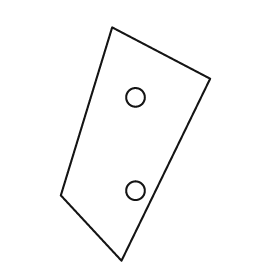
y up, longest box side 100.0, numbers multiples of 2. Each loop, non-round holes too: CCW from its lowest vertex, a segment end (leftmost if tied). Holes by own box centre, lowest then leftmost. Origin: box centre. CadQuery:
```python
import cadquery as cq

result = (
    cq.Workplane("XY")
    .moveTo(-6.0, -50.0)
    .lineTo(32.0, 28.0)
    .lineTo(-10.0, 50.0)
    .lineTo(-32.0, -22.0)
    .close()
    .moveTo(0.0, -20.0)
    .circle(4.0)
    .moveTo(0.0, 20.0)
    .circle(4.0)
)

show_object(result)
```